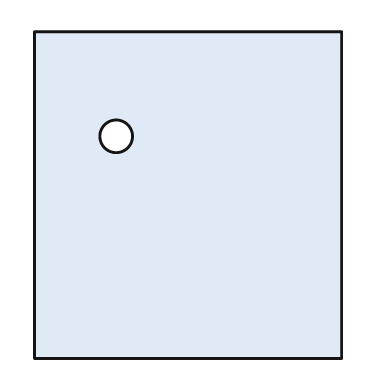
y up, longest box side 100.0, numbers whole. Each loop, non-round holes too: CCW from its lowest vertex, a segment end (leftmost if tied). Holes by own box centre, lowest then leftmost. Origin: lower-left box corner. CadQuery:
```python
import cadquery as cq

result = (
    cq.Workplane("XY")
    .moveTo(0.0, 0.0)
    .lineTo(94.0, 0.0)
    .lineTo(94.0, 100.0)
    .lineTo(0.0, 100.0)
    .close()
    .moveTo(25.0, 68.0)
    .circle(5.0)
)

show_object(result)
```